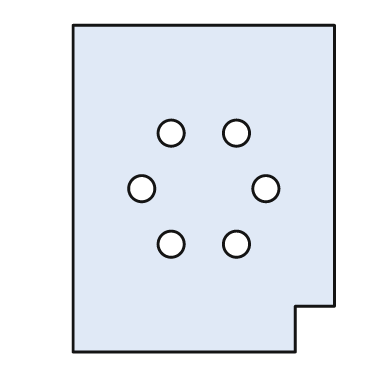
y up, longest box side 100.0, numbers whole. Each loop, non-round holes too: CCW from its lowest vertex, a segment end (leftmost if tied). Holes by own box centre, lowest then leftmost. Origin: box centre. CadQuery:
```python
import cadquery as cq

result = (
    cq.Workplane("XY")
    .moveTo(-40.0, -50.0)
    .lineTo(28.0, -50.0)
    .lineTo(28.0, -36.0)
    .lineTo(40.0, -36.0)
    .lineTo(40.0, 50.0)
    .lineTo(-40.0, 50.0)
    .close()
    .moveTo(-10.0, -17.0)
    .circle(4.0)
    .moveTo(10.0, -17.0)
    .circle(4.0)
    .moveTo(-19.0, 0.0)
    .circle(4.0)
    .moveTo(19.0, 0.0)
    .circle(4.0)
    .moveTo(-10.0, 17.0)
    .circle(4.0)
    .moveTo(10.0, 17.0)
    .circle(4.0)
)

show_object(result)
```